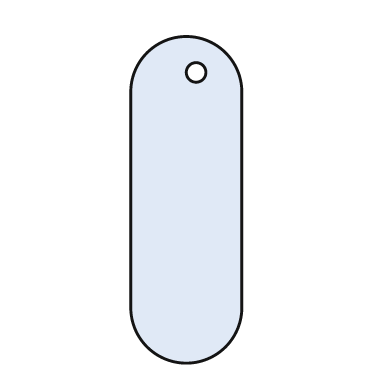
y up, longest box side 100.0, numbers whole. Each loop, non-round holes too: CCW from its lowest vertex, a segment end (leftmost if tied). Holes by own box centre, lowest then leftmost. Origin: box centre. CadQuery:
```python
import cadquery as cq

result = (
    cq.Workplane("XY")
    .moveTo(-17.0, -33.0)
    .threePointArc((0.0, -50.0), (17.0, -33.0))
    .lineTo(17.0, 33.0)
    .threePointArc((0.0, 50.0), (-17.0, 33.0))
    .close()
    .moveTo(3.0, 39.0)
    .circle(3.0)
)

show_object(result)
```